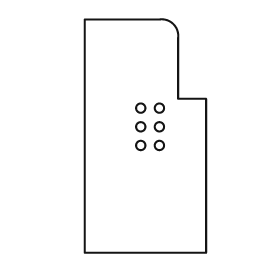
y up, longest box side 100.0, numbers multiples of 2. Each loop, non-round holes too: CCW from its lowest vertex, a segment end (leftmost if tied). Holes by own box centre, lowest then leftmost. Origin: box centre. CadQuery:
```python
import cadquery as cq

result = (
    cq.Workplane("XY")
    .moveTo(-26.0, -50.0)
    .lineTo(26.0, -50.0)
    .lineTo(26.0, 16.0)
    .lineTo(14.0, 16.0)
    .lineTo(14.0, 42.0)
    .threePointArc((12.0, 48.0), (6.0, 50.0))
    .lineTo(-26.0, 50.0)
    .close()
    .moveTo(-2.0, -4.0)
    .circle(2.0)
    .moveTo(6.0, -4.0)
    .circle(2.0)
    .moveTo(-2.0, 4.0)
    .circle(2.0)
    .moveTo(6.0, 4.0)
    .circle(2.0)
    .moveTo(-2.0, 12.0)
    .circle(2.0)
    .moveTo(6.0, 12.0)
    .circle(2.0)
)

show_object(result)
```